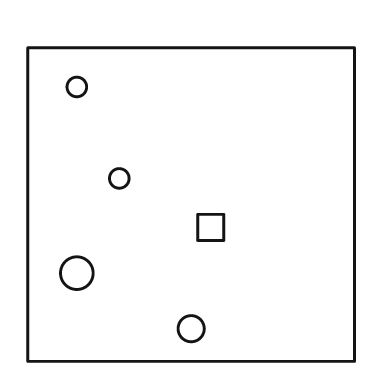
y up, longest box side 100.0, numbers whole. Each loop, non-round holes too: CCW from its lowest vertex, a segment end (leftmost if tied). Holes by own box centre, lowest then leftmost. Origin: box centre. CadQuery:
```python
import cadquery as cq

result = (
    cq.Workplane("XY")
    .moveTo(-50.0, -48.0)
    .lineTo(50.0, -48.0)
    .lineTo(50.0, 48.0)
    .lineTo(-50.0, 48.0)
    .close()
    .moveTo(0.0, -38.0)
    .circle(4.0)
    .moveTo(-35.0, -21.0)
    .circle(5.0)
    .moveTo(2.0, -11.0)
    .lineTo(10.0, -11.0)
    .lineTo(10.0, -3.0)
    .lineTo(2.0, -3.0)
    .close()
    .moveTo(-22.0, 8.0)
    .circle(3.0)
    .moveTo(-35.0, 36.0)
    .circle(3.0)
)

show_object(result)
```